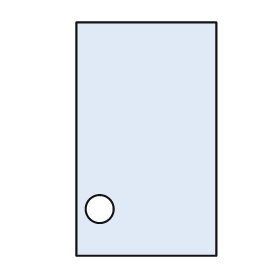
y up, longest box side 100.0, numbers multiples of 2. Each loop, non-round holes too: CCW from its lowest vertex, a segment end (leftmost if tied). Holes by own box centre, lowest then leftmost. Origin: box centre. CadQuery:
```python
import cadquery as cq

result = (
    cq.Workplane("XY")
    .moveTo(-30.0, -50.0)
    .lineTo(30.0, -50.0)
    .lineTo(30.0, 50.0)
    .lineTo(-30.0, 50.0)
    .close()
    .moveTo(-20.0, -30.0)
    .circle(6.0)
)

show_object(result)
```